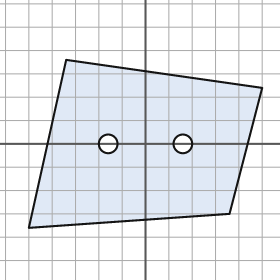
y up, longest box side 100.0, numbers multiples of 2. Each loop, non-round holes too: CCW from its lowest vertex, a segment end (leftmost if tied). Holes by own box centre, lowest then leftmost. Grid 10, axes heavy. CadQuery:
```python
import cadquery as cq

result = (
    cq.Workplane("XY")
    .moveTo(-50.0, -36.0)
    .lineTo(36.0, -30.0)
    .lineTo(50.0, 24.0)
    .lineTo(-34.0, 36.0)
    .close()
    .moveTo(-16.0, 0.0)
    .circle(4.0)
    .moveTo(16.0, 0.0)
    .circle(4.0)
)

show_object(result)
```